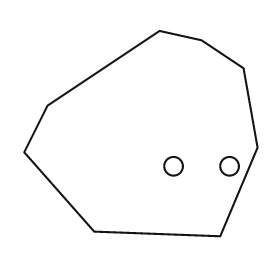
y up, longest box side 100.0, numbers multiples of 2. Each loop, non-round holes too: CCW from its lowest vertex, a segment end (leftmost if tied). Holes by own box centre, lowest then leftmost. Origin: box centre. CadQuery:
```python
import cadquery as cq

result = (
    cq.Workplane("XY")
    .moveTo(34.0, -44.0)
    .lineTo(50.0, -6.0)
    .lineTo(44.0, 28.0)
    .lineTo(26.0, 40.0)
    .lineTo(8.0, 44.0)
    .lineTo(-40.0, 12.0)
    .lineTo(-50.0, -8.0)
    .lineTo(-20.0, -42.0)
    .close()
    .moveTo(14.0, -14.0)
    .circle(4.0)
    .moveTo(38.0, -14.0)
    .circle(4.0)
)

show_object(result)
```